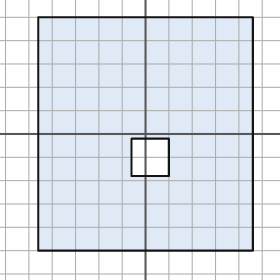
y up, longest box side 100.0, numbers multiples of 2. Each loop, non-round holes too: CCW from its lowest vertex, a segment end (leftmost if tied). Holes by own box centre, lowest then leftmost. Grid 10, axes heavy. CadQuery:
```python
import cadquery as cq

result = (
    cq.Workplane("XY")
    .moveTo(-46.0, -50.0)
    .lineTo(46.0, -50.0)
    .lineTo(46.0, 50.0)
    .lineTo(-46.0, 50.0)
    .close()
    .moveTo(-6.0, -18.0)
    .lineTo(10.0, -18.0)
    .lineTo(10.0, -2.0)
    .lineTo(-6.0, -2.0)
    .close()
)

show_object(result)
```